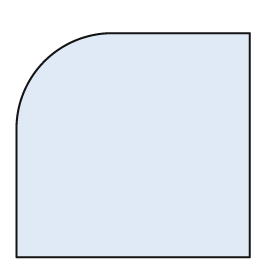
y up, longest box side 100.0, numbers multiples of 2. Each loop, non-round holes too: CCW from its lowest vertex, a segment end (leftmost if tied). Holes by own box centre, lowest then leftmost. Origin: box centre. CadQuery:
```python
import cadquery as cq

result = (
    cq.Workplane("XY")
    .moveTo(-50.0, -48.0)
    .lineTo(50.0, -48.0)
    .lineTo(50.0, 48.0)
    .lineTo(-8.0, 48.0)
    .threePointArc((-38.0, 36.0), (-50.0, 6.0))
    .close()
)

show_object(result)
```